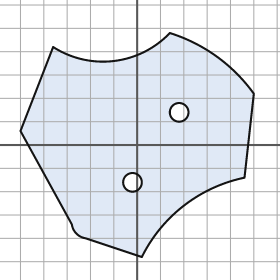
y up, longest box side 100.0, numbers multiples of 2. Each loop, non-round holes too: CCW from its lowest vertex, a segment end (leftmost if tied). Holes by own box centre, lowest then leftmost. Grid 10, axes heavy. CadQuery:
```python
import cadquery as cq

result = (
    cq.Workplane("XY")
    .moveTo(2.0, -48.0)
    .threePointArc((20.0, -26.0), (46.0, -14.0))
    .lineTo(50.0, 22.0)
    .threePointArc((34.0, 38.0), (14.0, 48.0))
    .threePointArc((-10.0, 36.0), (-36.0, 42.0))
    .lineTo(-50.0, 6.0)
    .lineTo(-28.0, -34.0)
    .threePointArc((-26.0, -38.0), (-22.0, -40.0))
    .close()
    .moveTo(-2.0, -16.0)
    .circle(4.0)
    .moveTo(18.0, 14.0)
    .circle(4.0)
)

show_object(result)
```